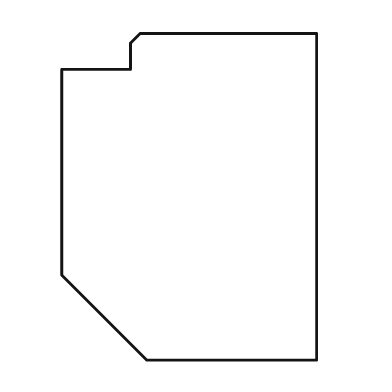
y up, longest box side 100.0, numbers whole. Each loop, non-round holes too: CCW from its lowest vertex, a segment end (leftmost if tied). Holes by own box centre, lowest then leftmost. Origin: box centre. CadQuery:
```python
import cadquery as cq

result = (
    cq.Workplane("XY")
    .moveTo(-13.0, -50.0)
    .lineTo(39.0, -50.0)
    .lineTo(39.0, 50.0)
    .lineTo(-15.0, 50.0)
    .lineTo(-18.0, 47.0)
    .lineTo(-18.0, 39.0)
    .lineTo(-39.0, 39.0)
    .lineTo(-39.0, -24.0)
    .close()
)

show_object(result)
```